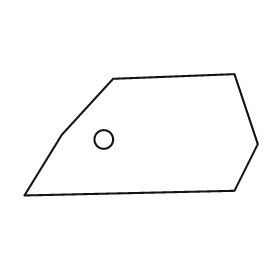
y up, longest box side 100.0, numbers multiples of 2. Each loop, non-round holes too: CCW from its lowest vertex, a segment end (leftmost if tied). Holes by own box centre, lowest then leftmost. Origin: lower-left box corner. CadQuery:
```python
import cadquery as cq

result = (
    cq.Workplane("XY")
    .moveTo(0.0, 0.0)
    .lineTo(90.0, 2.0)
    .lineTo(100.0, 22.0)
    .lineTo(90.0, 52.0)
    .lineTo(38.0, 50.0)
    .lineTo(16.0, 26.0)
    .close()
    .moveTo(34.0, 24.0)
    .circle(4.0)
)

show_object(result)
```